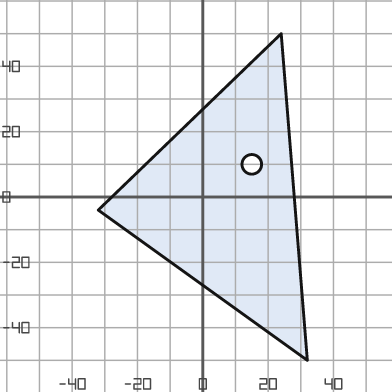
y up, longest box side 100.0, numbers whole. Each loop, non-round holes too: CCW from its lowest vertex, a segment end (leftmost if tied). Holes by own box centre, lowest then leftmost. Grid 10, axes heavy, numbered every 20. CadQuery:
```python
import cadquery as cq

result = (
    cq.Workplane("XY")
    .moveTo(32.0, -50.0)
    .lineTo(24.0, 50.0)
    .lineTo(-32.0, -4.0)
    .close()
    .moveTo(15.0, 10.0)
    .circle(3.0)
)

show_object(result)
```